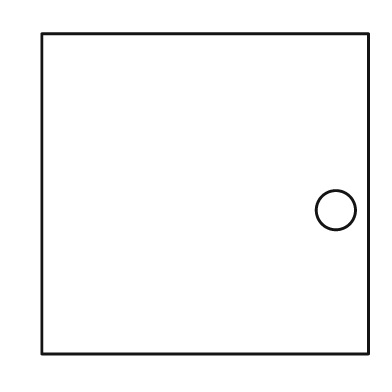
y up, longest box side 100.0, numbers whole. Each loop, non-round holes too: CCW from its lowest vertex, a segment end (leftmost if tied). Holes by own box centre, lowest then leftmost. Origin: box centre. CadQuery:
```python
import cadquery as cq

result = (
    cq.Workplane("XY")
    .moveTo(-50.0, -49.0)
    .lineTo(50.0, -49.0)
    .lineTo(50.0, 49.0)
    .lineTo(-50.0, 49.0)
    .close()
    .moveTo(40.0, -5.0)
    .circle(6.0)
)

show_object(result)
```